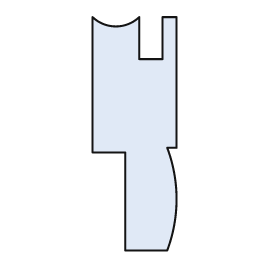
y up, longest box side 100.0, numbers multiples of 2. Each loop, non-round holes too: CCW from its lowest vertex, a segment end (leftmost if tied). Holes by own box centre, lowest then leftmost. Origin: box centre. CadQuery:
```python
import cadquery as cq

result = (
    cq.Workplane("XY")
    .moveTo(-4.0, -50.0)
    .lineTo(14.0, -50.0)
    .threePointArc((18.0, -28.0), (14.0, -6.0))
    .lineTo(18.0, -6.0)
    .lineTo(18.0, 50.0)
    .lineTo(12.0, 50.0)
    .lineTo(12.0, 32.0)
    .lineTo(2.0, 32.0)
    .lineTo(2.0, 50.0)
    .threePointArc((-8.0, 46.0), (-18.0, 50.0))
    .lineTo(-18.0, -8.0)
    .lineTo(-4.0, -8.0)
    .close()
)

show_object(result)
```